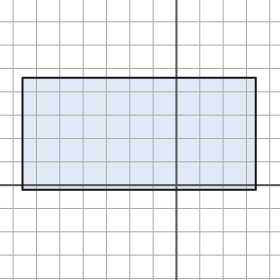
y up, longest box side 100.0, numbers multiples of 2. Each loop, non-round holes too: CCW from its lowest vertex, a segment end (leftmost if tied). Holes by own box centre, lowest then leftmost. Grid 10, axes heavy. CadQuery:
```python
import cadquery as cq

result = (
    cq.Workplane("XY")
    .moveTo(-66.0, -2.0)
    .lineTo(34.0, -2.0)
    .lineTo(34.0, 46.0)
    .lineTo(-66.0, 46.0)
    .close()
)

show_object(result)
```